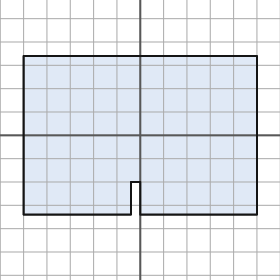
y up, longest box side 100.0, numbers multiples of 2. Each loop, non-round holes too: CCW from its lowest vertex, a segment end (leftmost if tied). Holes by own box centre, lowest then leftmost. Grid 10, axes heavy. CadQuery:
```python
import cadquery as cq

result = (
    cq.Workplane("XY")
    .moveTo(-50.0, -34.0)
    .lineTo(-4.0, -34.0)
    .lineTo(-4.0, -20.0)
    .lineTo(0.0, -20.0)
    .lineTo(0.0, -34.0)
    .lineTo(50.0, -34.0)
    .lineTo(50.0, 34.0)
    .lineTo(-50.0, 34.0)
    .close()
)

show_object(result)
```